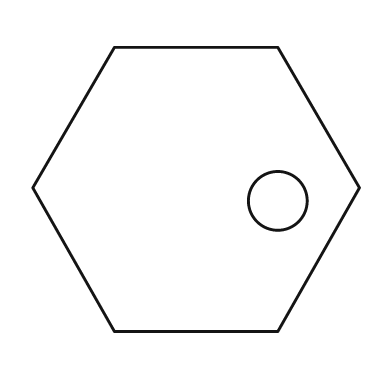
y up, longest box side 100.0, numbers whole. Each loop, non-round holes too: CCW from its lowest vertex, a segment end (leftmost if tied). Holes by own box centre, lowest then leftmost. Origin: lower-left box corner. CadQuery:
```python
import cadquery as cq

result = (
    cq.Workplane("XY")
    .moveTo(25.0, 0.0)
    .lineTo(75.0, 0.0)
    .lineTo(100.0, 44.0)
    .lineTo(75.0, 87.0)
    .lineTo(25.0, 87.0)
    .lineTo(0.0, 44.0)
    .close()
    .moveTo(75.0, 40.0)
    .circle(9.0)
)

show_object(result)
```